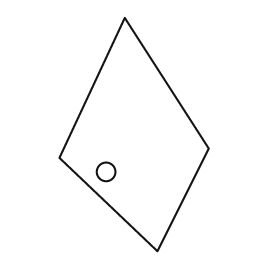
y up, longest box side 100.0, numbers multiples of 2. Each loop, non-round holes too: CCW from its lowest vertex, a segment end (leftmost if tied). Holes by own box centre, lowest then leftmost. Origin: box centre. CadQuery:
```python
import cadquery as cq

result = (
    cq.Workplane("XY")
    .moveTo(10.0, -50.0)
    .lineTo(32.0, -6.0)
    .lineTo(-4.0, 50.0)
    .lineTo(-32.0, -10.0)
    .close()
    .moveTo(-12.0, -16.0)
    .circle(4.0)
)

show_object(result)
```